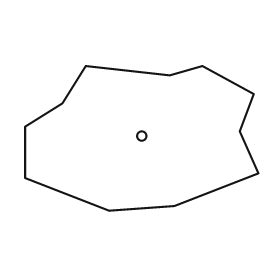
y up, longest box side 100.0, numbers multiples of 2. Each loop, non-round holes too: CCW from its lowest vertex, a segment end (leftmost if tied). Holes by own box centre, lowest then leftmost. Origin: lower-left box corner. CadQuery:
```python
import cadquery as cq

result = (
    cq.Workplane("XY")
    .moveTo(36.0, 0.0)
    .lineTo(64.0, 2.0)
    .lineTo(100.0, 16.0)
    .lineTo(92.0, 34.0)
    .lineTo(98.0, 50.0)
    .lineTo(76.0, 62.0)
    .lineTo(62.0, 58.0)
    .lineTo(26.0, 62.0)
    .lineTo(16.0, 46.0)
    .lineTo(0.0, 36.0)
    .lineTo(0.0, 14.0)
    .close()
    .moveTo(50.0, 32.0)
    .circle(2.0)
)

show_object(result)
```